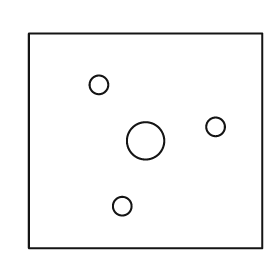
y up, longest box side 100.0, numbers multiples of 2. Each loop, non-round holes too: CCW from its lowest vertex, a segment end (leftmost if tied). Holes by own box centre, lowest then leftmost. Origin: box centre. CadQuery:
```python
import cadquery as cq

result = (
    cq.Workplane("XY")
    .moveTo(-50.0, -46.0)
    .lineTo(50.0, -46.0)
    .lineTo(50.0, 46.0)
    .lineTo(-50.0, 46.0)
    .close()
    .moveTo(-10.0, -28.0)
    .circle(4.0)
    .moveTo(0.0, 0.0)
    .circle(8.0)
    .moveTo(30.0, 6.0)
    .circle(4.0)
    .moveTo(-20.0, 24.0)
    .circle(4.0)
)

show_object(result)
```